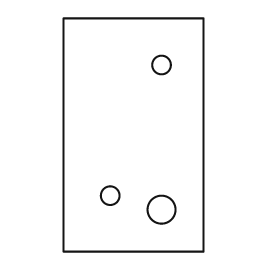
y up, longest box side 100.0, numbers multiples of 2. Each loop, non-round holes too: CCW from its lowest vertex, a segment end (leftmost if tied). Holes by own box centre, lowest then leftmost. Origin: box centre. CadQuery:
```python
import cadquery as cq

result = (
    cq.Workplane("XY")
    .moveTo(-30.0, -50.0)
    .lineTo(30.0, -50.0)
    .lineTo(30.0, 50.0)
    .lineTo(-30.0, 50.0)
    .close()
    .moveTo(12.0, -32.0)
    .circle(6.0)
    .moveTo(-10.0, -26.0)
    .circle(4.0)
    .moveTo(12.0, 30.0)
    .circle(4.0)
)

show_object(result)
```